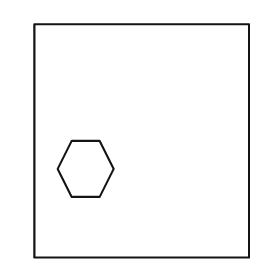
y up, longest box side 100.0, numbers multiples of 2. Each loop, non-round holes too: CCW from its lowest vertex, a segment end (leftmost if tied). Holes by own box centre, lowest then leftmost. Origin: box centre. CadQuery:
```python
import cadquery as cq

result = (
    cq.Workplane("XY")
    .moveTo(-46.0, -50.0)
    .lineTo(46.0, -50.0)
    .lineTo(46.0, 50.0)
    .lineTo(-46.0, 50.0)
    .close()
    .moveTo(-30.0, -24.0)
    .lineTo(-18.0, -24.0)
    .lineTo(-12.0, -12.0)
    .lineTo(-18.0, 0.0)
    .lineTo(-30.0, 0.0)
    .lineTo(-36.0, -12.0)
    .close()
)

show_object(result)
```